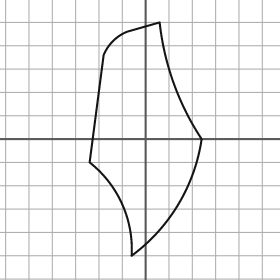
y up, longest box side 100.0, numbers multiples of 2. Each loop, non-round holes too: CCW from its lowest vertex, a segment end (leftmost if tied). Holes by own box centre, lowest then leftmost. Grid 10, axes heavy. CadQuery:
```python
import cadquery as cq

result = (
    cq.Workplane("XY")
    .moveTo(-6.0, -50.0)
    .threePointArc((14.0, -28.0), (24.0, 0.0))
    .threePointArc((12.0, 24.0), (6.0, 50.0))
    .lineTo(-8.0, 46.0)
    .threePointArc((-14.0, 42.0), (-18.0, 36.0))
    .lineTo(-24.0, -10.0)
    .threePointArc((-10.0, -28.0), (-6.0, -50.0))
    .close()
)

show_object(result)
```